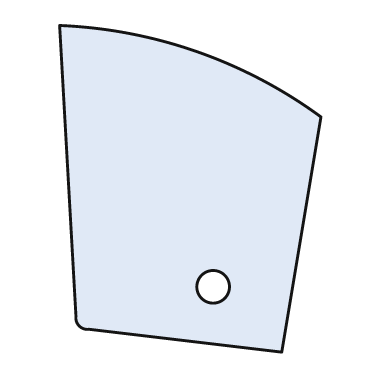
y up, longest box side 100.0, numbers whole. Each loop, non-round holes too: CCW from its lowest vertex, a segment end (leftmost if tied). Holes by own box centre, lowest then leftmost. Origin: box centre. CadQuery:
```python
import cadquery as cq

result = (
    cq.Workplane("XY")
    .moveTo(28.0, -50.0)
    .lineTo(40.0, 22.0)
    .threePointArc((2.0, 42.0), (-40.0, 50.0))
    .lineTo(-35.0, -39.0)
    .threePointArc((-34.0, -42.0), (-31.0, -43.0))
    .close()
    .moveTo(7.0, -30.0)
    .circle(5.0)
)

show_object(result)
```